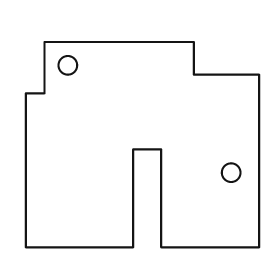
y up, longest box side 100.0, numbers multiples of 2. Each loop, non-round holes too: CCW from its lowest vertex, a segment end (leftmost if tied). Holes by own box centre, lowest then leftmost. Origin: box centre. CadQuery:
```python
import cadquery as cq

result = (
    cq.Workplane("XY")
    .moveTo(-50.0, -44.0)
    .lineTo(-4.0, -44.0)
    .lineTo(-4.0, -2.0)
    .lineTo(8.0, -2.0)
    .lineTo(8.0, -44.0)
    .lineTo(50.0, -44.0)
    .lineTo(50.0, 30.0)
    .lineTo(22.0, 30.0)
    .lineTo(22.0, 44.0)
    .lineTo(-42.0, 44.0)
    .lineTo(-42.0, 22.0)
    .lineTo(-50.0, 22.0)
    .close()
    .moveTo(38.0, -12.0)
    .circle(4.0)
    .moveTo(-32.0, 34.0)
    .circle(4.0)
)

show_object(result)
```